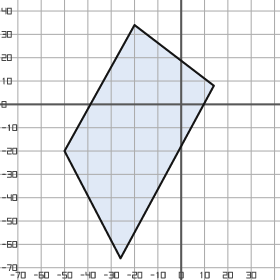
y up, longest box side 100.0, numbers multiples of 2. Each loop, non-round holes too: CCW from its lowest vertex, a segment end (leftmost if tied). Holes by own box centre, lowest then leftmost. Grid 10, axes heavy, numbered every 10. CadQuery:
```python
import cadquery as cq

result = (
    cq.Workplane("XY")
    .moveTo(-26.0, -66.0)
    .lineTo(14.0, 8.0)
    .lineTo(-20.0, 34.0)
    .lineTo(-50.0, -20.0)
    .close()
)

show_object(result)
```